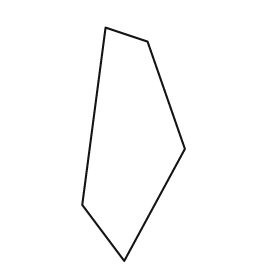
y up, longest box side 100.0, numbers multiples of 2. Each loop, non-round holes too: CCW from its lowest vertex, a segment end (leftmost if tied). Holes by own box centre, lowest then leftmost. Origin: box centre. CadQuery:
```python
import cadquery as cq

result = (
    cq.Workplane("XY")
    .moveTo(-4.0, -50.0)
    .lineTo(22.0, -2.0)
    .lineTo(6.0, 44.0)
    .lineTo(-12.0, 50.0)
    .lineTo(-22.0, -26.0)
    .close()
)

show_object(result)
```